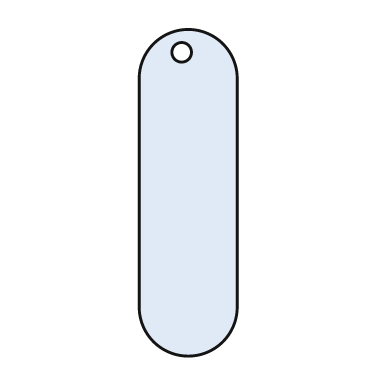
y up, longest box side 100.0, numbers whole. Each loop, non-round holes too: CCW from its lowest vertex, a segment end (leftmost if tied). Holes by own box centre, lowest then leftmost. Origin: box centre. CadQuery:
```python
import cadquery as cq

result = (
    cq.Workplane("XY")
    .moveTo(-15.0, -35.0)
    .threePointArc((0.0, -50.0), (15.0, -35.0))
    .lineTo(15.0, 35.0)
    .threePointArc((0.0, 50.0), (-15.0, 35.0))
    .close()
    .moveTo(-2.0, 43.0)
    .circle(3.0)
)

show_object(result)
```